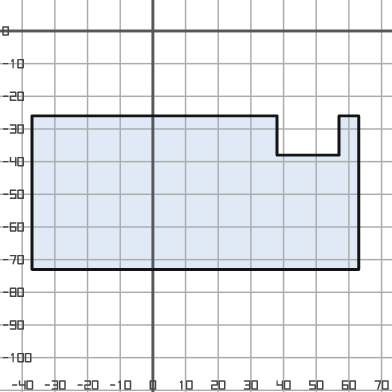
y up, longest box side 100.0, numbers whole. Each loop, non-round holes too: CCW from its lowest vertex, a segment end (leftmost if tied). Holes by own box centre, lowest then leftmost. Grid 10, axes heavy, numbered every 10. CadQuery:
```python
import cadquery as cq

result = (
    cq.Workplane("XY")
    .moveTo(-37.0, -73.0)
    .lineTo(63.0, -73.0)
    .lineTo(63.0, -26.0)
    .lineTo(57.0, -26.0)
    .lineTo(57.0, -38.0)
    .lineTo(38.0, -38.0)
    .lineTo(38.0, -26.0)
    .lineTo(-37.0, -26.0)
    .close()
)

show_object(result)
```